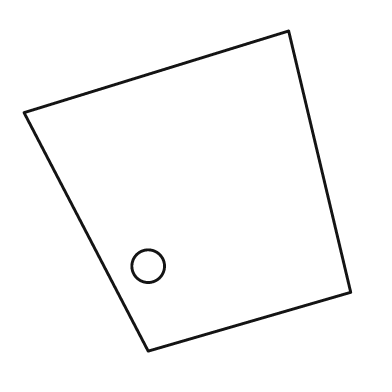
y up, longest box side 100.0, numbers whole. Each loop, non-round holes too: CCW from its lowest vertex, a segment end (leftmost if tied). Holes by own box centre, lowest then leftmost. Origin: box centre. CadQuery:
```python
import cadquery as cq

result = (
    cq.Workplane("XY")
    .moveTo(-12.0, -49.0)
    .lineTo(50.0, -31.0)
    .lineTo(31.0, 49.0)
    .lineTo(-50.0, 24.0)
    .close()
    .moveTo(-12.0, -23.0)
    .circle(5.0)
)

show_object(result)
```